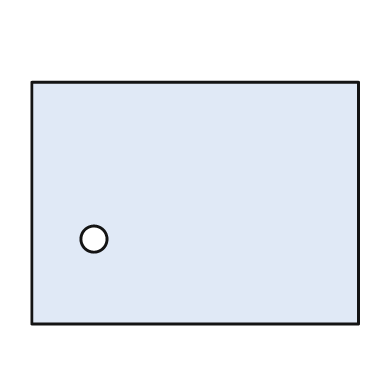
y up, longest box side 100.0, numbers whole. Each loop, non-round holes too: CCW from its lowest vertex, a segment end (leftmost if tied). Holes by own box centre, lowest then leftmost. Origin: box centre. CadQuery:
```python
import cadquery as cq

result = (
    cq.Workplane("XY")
    .moveTo(-50.0, -37.0)
    .lineTo(50.0, -37.0)
    .lineTo(50.0, 37.0)
    .lineTo(-50.0, 37.0)
    .close()
    .moveTo(-31.0, -11.0)
    .circle(4.0)
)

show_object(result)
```